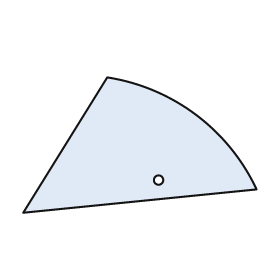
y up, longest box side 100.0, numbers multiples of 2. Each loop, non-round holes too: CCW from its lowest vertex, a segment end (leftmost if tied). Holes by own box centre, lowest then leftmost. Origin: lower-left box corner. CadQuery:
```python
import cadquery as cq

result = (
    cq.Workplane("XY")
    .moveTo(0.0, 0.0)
    .lineTo(100.0, 10.0)
    .threePointArc((74.0, 42.0), (36.0, 58.0))
    .close()
    .moveTo(58.0, 14.0)
    .circle(2.0)
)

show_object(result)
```